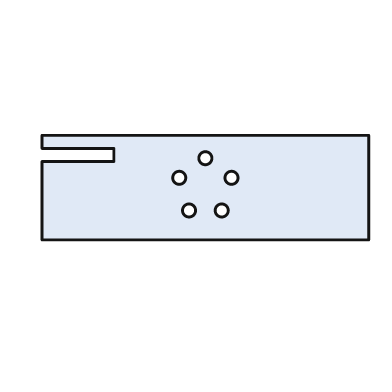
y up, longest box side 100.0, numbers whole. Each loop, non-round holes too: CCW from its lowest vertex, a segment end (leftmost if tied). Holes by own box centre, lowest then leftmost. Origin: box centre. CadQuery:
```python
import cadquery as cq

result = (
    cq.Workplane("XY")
    .moveTo(-50.0, -16.0)
    .lineTo(50.0, -16.0)
    .lineTo(50.0, 16.0)
    .lineTo(-50.0, 16.0)
    .lineTo(-50.0, 12.0)
    .lineTo(-28.0, 12.0)
    .lineTo(-28.0, 8.0)
    .lineTo(-50.0, 8.0)
    .close()
    .moveTo(-5.0, -7.0)
    .circle(2.0)
    .moveTo(5.0, -7.0)
    .circle(2.0)
    .moveTo(-8.0, 3.0)
    .circle(2.0)
    .moveTo(8.0, 3.0)
    .circle(2.0)
    .moveTo(0.0, 9.0)
    .circle(2.0)
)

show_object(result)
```